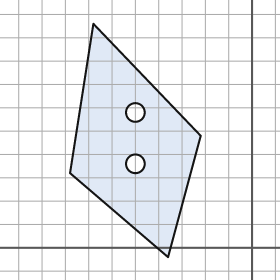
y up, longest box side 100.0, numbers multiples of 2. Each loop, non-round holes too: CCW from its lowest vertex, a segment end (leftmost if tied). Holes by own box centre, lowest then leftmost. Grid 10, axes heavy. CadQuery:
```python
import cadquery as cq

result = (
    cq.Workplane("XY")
    .moveTo(-36.0, -4.0)
    .lineTo(-22.0, 48.0)
    .lineTo(-68.0, 96.0)
    .lineTo(-78.0, 32.0)
    .close()
    .moveTo(-50.0, 36.0)
    .circle(4.0)
    .moveTo(-50.0, 58.0)
    .circle(4.0)
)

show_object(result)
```